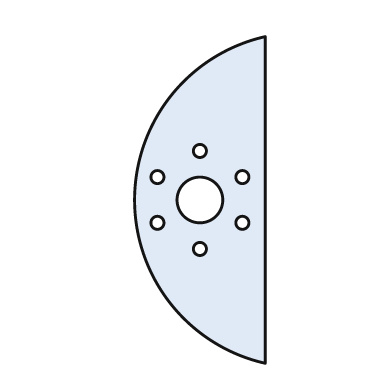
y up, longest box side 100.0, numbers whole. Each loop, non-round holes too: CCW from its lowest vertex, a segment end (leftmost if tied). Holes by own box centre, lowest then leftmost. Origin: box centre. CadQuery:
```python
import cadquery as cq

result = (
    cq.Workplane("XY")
    .moveTo(20.0, -50.0)
    .lineTo(20.0, 50.0)
    .threePointArc((-20.0, 0.0), (20.0, -50.0))
    .close()
    .moveTo(0.0, -15.0)
    .circle(2.0)
    .moveTo(-13.0, -7.0)
    .circle(2.0)
    .moveTo(13.0, -7.0)
    .circle(2.0)
    .moveTo(0.0, 0.0)
    .circle(7.0)
    .moveTo(-13.0, 7.0)
    .circle(2.0)
    .moveTo(13.0, 7.0)
    .circle(2.0)
    .moveTo(0.0, 15.0)
    .circle(2.0)
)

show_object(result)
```